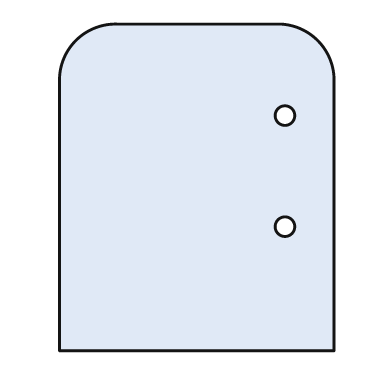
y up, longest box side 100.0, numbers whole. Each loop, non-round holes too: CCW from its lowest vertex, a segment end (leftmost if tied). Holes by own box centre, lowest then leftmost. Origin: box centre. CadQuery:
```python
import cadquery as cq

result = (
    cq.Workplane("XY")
    .moveTo(-42.0, -50.0)
    .lineTo(42.0, -50.0)
    .lineTo(42.0, 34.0)
    .threePointArc((37.0, 45.0), (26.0, 50.0))
    .lineTo(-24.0, 50.0)
    .threePointArc((-37.0, 45.0), (-42.0, 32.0))
    .close()
    .moveTo(27.0, -12.0)
    .circle(3.0)
    .moveTo(27.0, 22.0)
    .circle(3.0)
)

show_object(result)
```